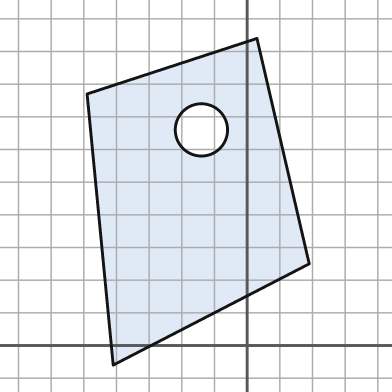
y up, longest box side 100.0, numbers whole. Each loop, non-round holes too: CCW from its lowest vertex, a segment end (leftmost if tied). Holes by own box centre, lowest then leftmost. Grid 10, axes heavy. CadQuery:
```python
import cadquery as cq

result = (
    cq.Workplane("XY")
    .moveTo(-41.0, -6.0)
    .lineTo(19.0, 25.0)
    .lineTo(3.0, 94.0)
    .lineTo(-49.0, 77.0)
    .close()
    .moveTo(-14.0, 66.0)
    .circle(8.0)
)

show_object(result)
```